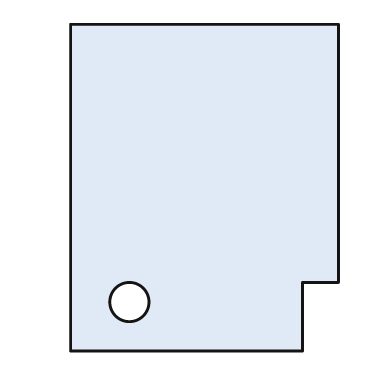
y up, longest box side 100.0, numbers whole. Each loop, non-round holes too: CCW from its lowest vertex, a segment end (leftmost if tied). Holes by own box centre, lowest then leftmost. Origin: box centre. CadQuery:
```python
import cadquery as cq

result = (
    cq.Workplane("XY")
    .moveTo(-41.0, -50.0)
    .lineTo(30.0, -50.0)
    .lineTo(30.0, -29.0)
    .lineTo(41.0, -29.0)
    .lineTo(41.0, 50.0)
    .lineTo(-41.0, 50.0)
    .close()
    .moveTo(-23.0, -35.0)
    .circle(6.0)
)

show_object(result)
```